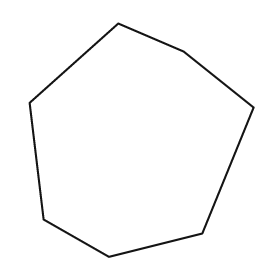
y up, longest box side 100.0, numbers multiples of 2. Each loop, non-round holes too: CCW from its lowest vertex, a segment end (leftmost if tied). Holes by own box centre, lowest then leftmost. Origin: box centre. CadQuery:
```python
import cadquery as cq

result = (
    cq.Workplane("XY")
    .moveTo(-14.0, -50.0)
    .lineTo(26.0, -40.0)
    .lineTo(48.0, 14.0)
    .lineTo(18.0, 38.0)
    .lineTo(-10.0, 50.0)
    .lineTo(-48.0, 16.0)
    .lineTo(-42.0, -34.0)
    .close()
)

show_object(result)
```